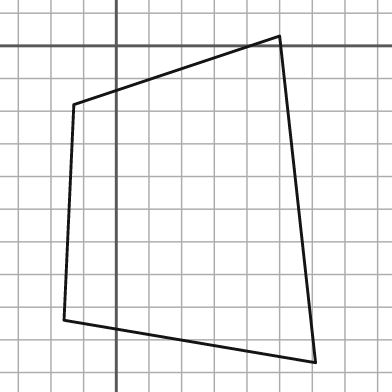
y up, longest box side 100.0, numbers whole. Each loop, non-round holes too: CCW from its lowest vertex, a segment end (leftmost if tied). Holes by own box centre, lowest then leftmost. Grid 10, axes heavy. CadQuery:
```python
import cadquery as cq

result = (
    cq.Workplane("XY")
    .moveTo(61.0, -97.0)
    .lineTo(50.0, 3.0)
    .lineTo(-13.0, -18.0)
    .lineTo(-16.0, -84.0)
    .close()
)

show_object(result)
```